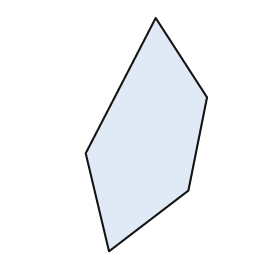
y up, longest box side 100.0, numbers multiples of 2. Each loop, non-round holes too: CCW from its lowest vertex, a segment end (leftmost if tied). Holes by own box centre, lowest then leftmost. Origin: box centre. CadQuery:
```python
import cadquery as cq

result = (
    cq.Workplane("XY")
    .moveTo(-16.0, -50.0)
    .lineTo(18.0, -24.0)
    .lineTo(26.0, 16.0)
    .lineTo(4.0, 50.0)
    .lineTo(-26.0, -8.0)
    .close()
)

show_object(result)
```